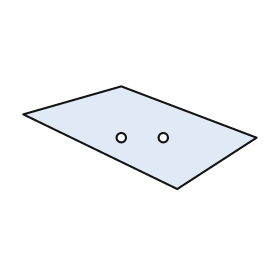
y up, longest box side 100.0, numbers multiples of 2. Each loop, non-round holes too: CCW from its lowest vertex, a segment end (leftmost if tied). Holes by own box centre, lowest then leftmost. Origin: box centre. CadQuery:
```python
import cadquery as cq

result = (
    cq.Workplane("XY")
    .moveTo(16.0, -22.0)
    .lineTo(50.0, 0.0)
    .lineTo(-8.0, 22.0)
    .lineTo(-50.0, 10.0)
    .close()
    .moveTo(-8.0, 0.0)
    .circle(2.0)
    .moveTo(10.0, 0.0)
    .circle(2.0)
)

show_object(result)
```